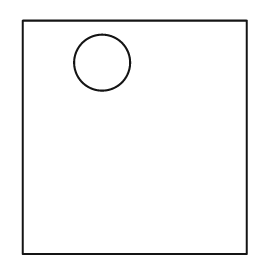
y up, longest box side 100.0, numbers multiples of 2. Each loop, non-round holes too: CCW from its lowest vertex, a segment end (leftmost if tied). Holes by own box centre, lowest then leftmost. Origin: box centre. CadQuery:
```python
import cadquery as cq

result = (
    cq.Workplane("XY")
    .moveTo(-48.0, -50.0)
    .lineTo(48.0, -50.0)
    .lineTo(48.0, 50.0)
    .lineTo(-48.0, 50.0)
    .close()
    .moveTo(-14.0, 32.0)
    .circle(12.0)
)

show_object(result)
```